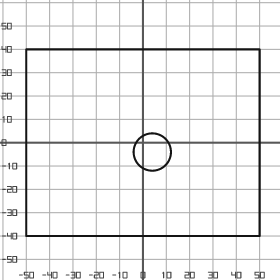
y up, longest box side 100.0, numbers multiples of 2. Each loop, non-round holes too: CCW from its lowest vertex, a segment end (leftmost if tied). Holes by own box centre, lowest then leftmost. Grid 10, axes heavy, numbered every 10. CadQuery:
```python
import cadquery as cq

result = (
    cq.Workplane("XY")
    .moveTo(-50.0, -40.0)
    .lineTo(50.0, -40.0)
    .lineTo(50.0, 40.0)
    .lineTo(-50.0, 40.0)
    .close()
    .moveTo(4.0, -4.0)
    .circle(8.0)
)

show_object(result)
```